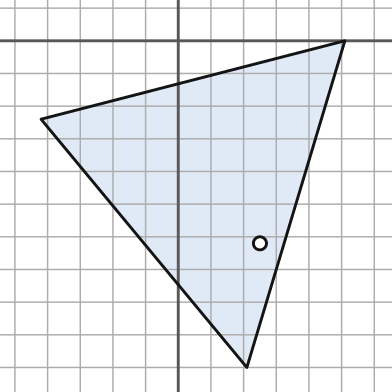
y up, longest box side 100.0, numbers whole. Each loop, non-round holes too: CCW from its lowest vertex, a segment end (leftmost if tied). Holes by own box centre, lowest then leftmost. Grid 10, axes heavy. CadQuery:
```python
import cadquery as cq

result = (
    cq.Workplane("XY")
    .moveTo(21.0, -100.0)
    .lineTo(51.0, 0.0)
    .lineTo(-42.0, -24.0)
    .close()
    .moveTo(25.0, -62.0)
    .circle(2.0)
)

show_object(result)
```